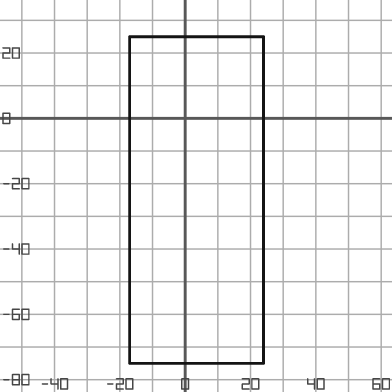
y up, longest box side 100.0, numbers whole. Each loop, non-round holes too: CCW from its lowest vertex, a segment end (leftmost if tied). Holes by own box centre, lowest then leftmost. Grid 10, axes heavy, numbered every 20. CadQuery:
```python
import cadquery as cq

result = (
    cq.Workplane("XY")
    .moveTo(-17.0, -75.0)
    .lineTo(24.0, -75.0)
    .lineTo(24.0, 25.0)
    .lineTo(-17.0, 25.0)
    .close()
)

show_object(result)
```